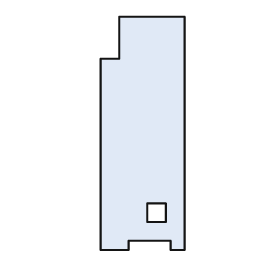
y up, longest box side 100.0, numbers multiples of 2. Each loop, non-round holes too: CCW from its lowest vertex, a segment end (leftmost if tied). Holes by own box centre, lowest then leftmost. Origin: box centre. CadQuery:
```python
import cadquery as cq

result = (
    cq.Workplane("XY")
    .moveTo(-18.0, -50.0)
    .lineTo(-6.0, -50.0)
    .lineTo(-6.0, -46.0)
    .lineTo(12.0, -46.0)
    .lineTo(12.0, -50.0)
    .lineTo(18.0, -50.0)
    .lineTo(18.0, 50.0)
    .lineTo(-10.0, 50.0)
    .lineTo(-10.0, 32.0)
    .lineTo(-18.0, 32.0)
    .close()
    .moveTo(2.0, -38.0)
    .lineTo(10.0, -38.0)
    .lineTo(10.0, -30.0)
    .lineTo(2.0, -30.0)
    .close()
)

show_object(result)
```